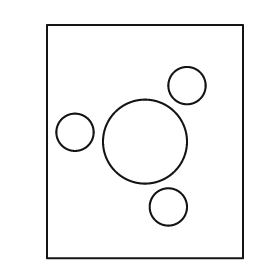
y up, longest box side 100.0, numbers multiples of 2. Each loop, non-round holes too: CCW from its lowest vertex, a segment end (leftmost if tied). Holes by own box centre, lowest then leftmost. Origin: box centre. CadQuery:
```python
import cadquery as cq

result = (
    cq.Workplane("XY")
    .moveTo(-42.0, -50.0)
    .lineTo(42.0, -50.0)
    .lineTo(42.0, 50.0)
    .lineTo(-42.0, 50.0)
    .close()
    .moveTo(10.0, -28.0)
    .circle(8.0)
    .moveTo(0.0, 0.0)
    .circle(18.0)
    .moveTo(-30.0, 4.0)
    .circle(8.0)
    .moveTo(18.0, 24.0)
    .circle(8.0)
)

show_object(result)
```